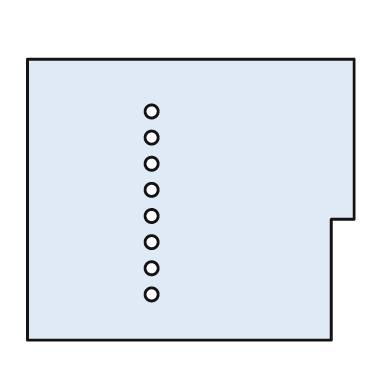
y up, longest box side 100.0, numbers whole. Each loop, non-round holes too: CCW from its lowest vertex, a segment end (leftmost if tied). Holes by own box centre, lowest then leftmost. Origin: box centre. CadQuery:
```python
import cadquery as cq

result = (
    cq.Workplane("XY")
    .moveTo(-50.0, -43.0)
    .lineTo(43.0, -43.0)
    .lineTo(43.0, -6.0)
    .lineTo(50.0, -6.0)
    .lineTo(50.0, 43.0)
    .lineTo(-50.0, 43.0)
    .close()
    .moveTo(-12.0, -29.0)
    .circle(2.0)
    .moveTo(-12.0, -21.0)
    .circle(2.0)
    .moveTo(-12.0, -13.0)
    .circle(2.0)
    .moveTo(-12.0, -5.0)
    .circle(2.0)
    .moveTo(-12.0, 3.0)
    .circle(2.0)
    .moveTo(-12.0, 11.0)
    .circle(2.0)
    .moveTo(-12.0, 19.0)
    .circle(2.0)
    .moveTo(-12.0, 27.0)
    .circle(2.0)
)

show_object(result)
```